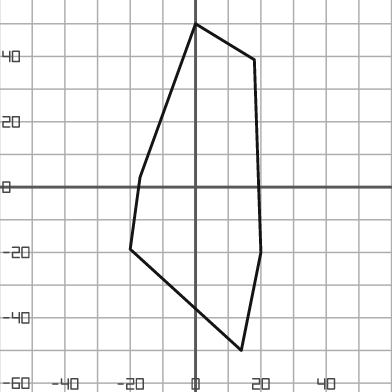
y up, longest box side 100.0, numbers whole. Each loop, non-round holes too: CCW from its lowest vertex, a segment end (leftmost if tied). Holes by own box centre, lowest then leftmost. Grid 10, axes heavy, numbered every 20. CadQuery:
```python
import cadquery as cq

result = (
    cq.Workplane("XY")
    .moveTo(14.0, -50.0)
    .lineTo(20.0, -20.0)
    .lineTo(18.0, 39.0)
    .lineTo(0.0, 50.0)
    .lineTo(-17.0, 3.0)
    .lineTo(-20.0, -19.0)
    .close()
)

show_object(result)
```